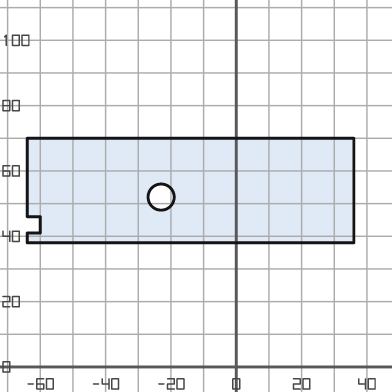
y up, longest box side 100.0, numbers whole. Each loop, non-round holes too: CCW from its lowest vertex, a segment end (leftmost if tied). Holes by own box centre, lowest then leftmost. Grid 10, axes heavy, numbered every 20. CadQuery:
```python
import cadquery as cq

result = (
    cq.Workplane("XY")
    .moveTo(-64.0, 38.0)
    .lineTo(36.0, 38.0)
    .lineTo(36.0, 70.0)
    .lineTo(-64.0, 70.0)
    .lineTo(-64.0, 46.0)
    .lineTo(-60.0, 46.0)
    .lineTo(-60.0, 41.0)
    .lineTo(-64.0, 41.0)
    .close()
    .moveTo(-23.0, 52.0)
    .circle(4.0)
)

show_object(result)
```